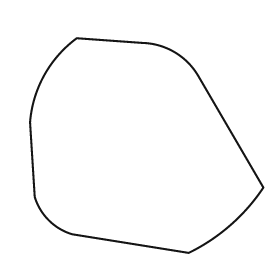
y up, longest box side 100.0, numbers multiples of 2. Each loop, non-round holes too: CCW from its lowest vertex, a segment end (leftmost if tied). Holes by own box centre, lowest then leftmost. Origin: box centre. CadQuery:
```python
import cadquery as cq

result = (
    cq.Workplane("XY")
    .moveTo(18.0, -46.0)
    .threePointArc((36.0, -34.0), (50.0, -18.0))
    .lineTo(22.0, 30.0)
    .threePointArc((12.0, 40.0), (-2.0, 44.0))
    .lineTo(-30.0, 46.0)
    .threePointArc((-44.0, 30.0), (-50.0, 10.0))
    .lineTo(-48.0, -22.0)
    .threePointArc((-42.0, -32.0), (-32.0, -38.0))
    .close()
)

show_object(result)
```